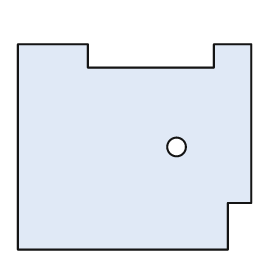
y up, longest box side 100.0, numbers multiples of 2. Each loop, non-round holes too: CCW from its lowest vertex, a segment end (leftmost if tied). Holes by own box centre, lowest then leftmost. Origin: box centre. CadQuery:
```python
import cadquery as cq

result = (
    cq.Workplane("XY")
    .moveTo(-50.0, -44.0)
    .lineTo(40.0, -44.0)
    .lineTo(40.0, -24.0)
    .lineTo(50.0, -24.0)
    .lineTo(50.0, 44.0)
    .lineTo(34.0, 44.0)
    .lineTo(34.0, 34.0)
    .lineTo(-20.0, 34.0)
    .lineTo(-20.0, 44.0)
    .lineTo(-50.0, 44.0)
    .close()
    .moveTo(18.0, 0.0)
    .circle(4.0)
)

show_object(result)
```